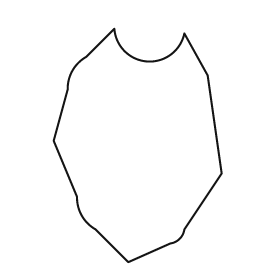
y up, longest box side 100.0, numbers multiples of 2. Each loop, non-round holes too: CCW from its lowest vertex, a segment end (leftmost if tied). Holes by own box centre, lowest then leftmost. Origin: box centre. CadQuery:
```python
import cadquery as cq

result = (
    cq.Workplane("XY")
    .moveTo(-4.0, -50.0)
    .lineTo(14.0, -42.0)
    .threePointArc((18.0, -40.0), (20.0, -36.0))
    .lineTo(36.0, -12.0)
    .lineTo(30.0, 30.0)
    .lineTo(20.0, 48.0)
    .threePointArc((4.0, 36.0), (-10.0, 50.0))
    .lineTo(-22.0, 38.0)
    .threePointArc((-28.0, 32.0), (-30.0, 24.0))
    .lineTo(-36.0, 2.0)
    .lineTo(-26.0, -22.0)
    .threePointArc((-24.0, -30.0), (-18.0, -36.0))
    .close()
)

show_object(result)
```